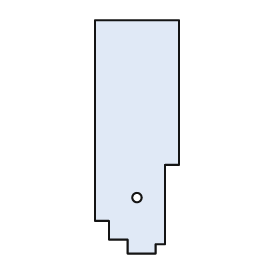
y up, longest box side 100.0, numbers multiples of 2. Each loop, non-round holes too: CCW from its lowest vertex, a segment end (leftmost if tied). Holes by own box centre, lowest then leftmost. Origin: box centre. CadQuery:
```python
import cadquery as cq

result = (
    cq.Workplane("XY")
    .moveTo(-4.0, -50.0)
    .lineTo(8.0, -50.0)
    .lineTo(8.0, -46.0)
    .lineTo(12.0, -46.0)
    .lineTo(12.0, -12.0)
    .lineTo(18.0, -12.0)
    .lineTo(18.0, 50.0)
    .lineTo(-18.0, 50.0)
    .lineTo(-18.0, -36.0)
    .lineTo(-12.0, -36.0)
    .lineTo(-12.0, -44.0)
    .lineTo(-4.0, -44.0)
    .close()
    .moveTo(0.0, -26.0)
    .circle(2.0)
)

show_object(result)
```